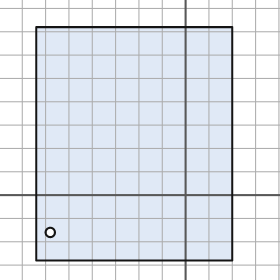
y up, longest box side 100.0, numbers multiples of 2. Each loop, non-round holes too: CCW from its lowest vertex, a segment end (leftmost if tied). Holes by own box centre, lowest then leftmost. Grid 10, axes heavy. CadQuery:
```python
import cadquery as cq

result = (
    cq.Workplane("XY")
    .moveTo(-64.0, -28.0)
    .lineTo(20.0, -28.0)
    .lineTo(20.0, 72.0)
    .lineTo(-64.0, 72.0)
    .close()
    .moveTo(-58.0, -16.0)
    .circle(2.0)
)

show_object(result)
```